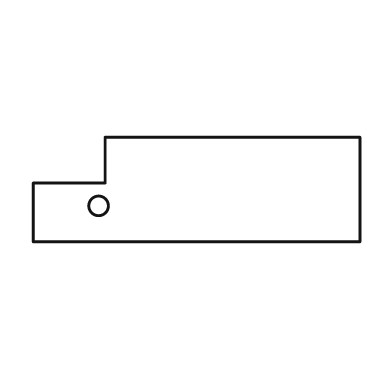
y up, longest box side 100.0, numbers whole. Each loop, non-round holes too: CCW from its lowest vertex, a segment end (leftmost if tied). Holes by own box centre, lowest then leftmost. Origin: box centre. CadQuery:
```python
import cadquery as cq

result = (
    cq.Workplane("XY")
    .moveTo(-50.0, -16.0)
    .lineTo(50.0, -16.0)
    .lineTo(50.0, 16.0)
    .lineTo(-28.0, 16.0)
    .lineTo(-28.0, 2.0)
    .lineTo(-50.0, 2.0)
    .close()
    .moveTo(-30.0, -5.0)
    .circle(3.0)
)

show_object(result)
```